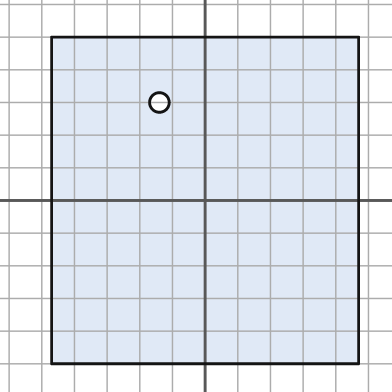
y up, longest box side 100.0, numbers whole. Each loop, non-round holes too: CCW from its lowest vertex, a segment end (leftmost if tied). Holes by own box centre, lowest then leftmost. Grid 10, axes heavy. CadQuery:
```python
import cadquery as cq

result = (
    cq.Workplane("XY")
    .moveTo(-47.0, -50.0)
    .lineTo(47.0, -50.0)
    .lineTo(47.0, 50.0)
    .lineTo(-47.0, 50.0)
    .close()
    .moveTo(-14.0, 30.0)
    .circle(3.0)
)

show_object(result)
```